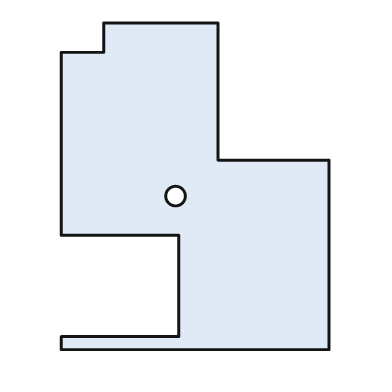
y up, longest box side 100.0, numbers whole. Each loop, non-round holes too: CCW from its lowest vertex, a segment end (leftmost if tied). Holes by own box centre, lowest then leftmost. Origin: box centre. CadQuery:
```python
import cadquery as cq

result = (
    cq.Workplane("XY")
    .moveTo(-41.0, -50.0)
    .lineTo(41.0, -50.0)
    .lineTo(41.0, 8.0)
    .lineTo(7.0, 8.0)
    .lineTo(7.0, 50.0)
    .lineTo(-28.0, 50.0)
    .lineTo(-28.0, 41.0)
    .lineTo(-41.0, 41.0)
    .lineTo(-41.0, -15.0)
    .lineTo(-5.0, -15.0)
    .lineTo(-5.0, -46.0)
    .lineTo(-41.0, -46.0)
    .close()
    .moveTo(-6.0, -3.0)
    .circle(3.0)
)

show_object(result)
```